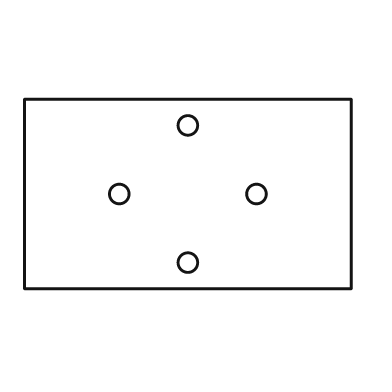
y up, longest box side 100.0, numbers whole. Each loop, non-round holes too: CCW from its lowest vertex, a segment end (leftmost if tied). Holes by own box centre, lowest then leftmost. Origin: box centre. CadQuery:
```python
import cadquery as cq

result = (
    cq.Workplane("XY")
    .moveTo(-50.0, -29.0)
    .lineTo(50.0, -29.0)
    .lineTo(50.0, 29.0)
    .lineTo(-50.0, 29.0)
    .close()
    .moveTo(0.0, -21.0)
    .circle(3.0)
    .moveTo(-21.0, 0.0)
    .circle(3.0)
    .moveTo(21.0, 0.0)
    .circle(3.0)
    .moveTo(0.0, 21.0)
    .circle(3.0)
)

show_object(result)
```